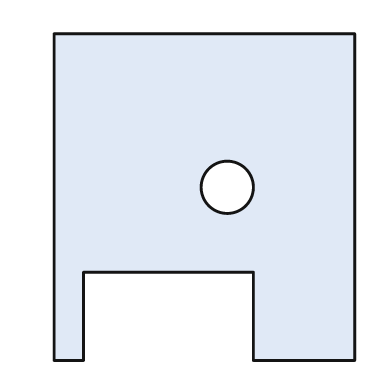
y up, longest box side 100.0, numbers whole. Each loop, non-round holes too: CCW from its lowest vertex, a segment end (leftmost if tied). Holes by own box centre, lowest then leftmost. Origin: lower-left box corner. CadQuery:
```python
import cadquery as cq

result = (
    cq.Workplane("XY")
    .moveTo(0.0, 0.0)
    .lineTo(9.0, 0.0)
    .lineTo(9.0, 27.0)
    .lineTo(61.0, 27.0)
    .lineTo(61.0, 0.0)
    .lineTo(92.0, 0.0)
    .lineTo(92.0, 100.0)
    .lineTo(0.0, 100.0)
    .close()
    .moveTo(53.0, 53.0)
    .circle(8.0)
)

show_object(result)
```